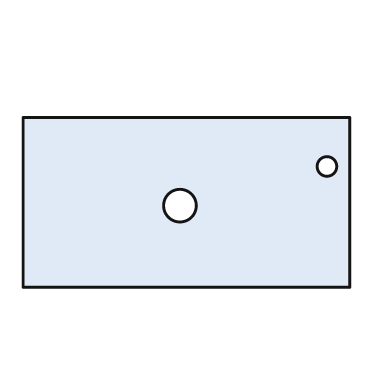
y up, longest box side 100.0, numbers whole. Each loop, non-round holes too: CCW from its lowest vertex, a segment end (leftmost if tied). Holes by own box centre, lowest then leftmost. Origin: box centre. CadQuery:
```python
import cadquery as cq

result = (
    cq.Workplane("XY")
    .moveTo(-50.0, -26.0)
    .lineTo(50.0, -26.0)
    .lineTo(50.0, 26.0)
    .lineTo(-50.0, 26.0)
    .close()
    .moveTo(-2.0, -1.0)
    .circle(5.0)
    .moveTo(43.0, 11.0)
    .circle(3.0)
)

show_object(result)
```